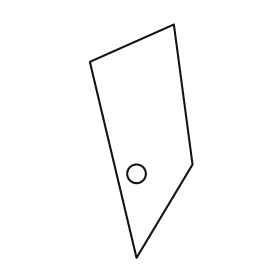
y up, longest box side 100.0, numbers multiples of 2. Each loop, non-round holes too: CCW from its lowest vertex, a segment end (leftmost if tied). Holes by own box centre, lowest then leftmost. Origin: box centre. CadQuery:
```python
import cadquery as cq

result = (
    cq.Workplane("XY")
    .moveTo(-2.0, -50.0)
    .lineTo(22.0, -10.0)
    .lineTo(14.0, 50.0)
    .lineTo(-22.0, 34.0)
    .close()
    .moveTo(-2.0, -14.0)
    .circle(4.0)
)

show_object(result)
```